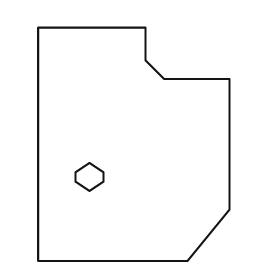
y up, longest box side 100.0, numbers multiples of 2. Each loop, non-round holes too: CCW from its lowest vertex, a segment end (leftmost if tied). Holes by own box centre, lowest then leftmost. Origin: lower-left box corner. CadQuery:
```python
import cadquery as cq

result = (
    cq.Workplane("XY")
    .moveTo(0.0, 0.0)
    .lineTo(64.0, 0.0)
    .lineTo(82.0, 22.0)
    .lineTo(82.0, 78.0)
    .lineTo(54.0, 78.0)
    .lineTo(46.0, 86.0)
    .lineTo(46.0, 100.0)
    .lineTo(0.0, 100.0)
    .close()
    .moveTo(22.0, 30.0)
    .lineTo(28.0, 34.0)
    .lineTo(28.0, 38.0)
    .lineTo(22.0, 42.0)
    .lineTo(16.0, 38.0)
    .lineTo(16.0, 34.0)
    .close()
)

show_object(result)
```